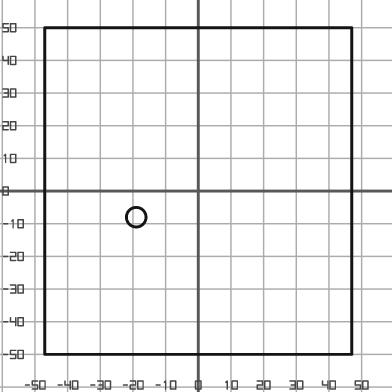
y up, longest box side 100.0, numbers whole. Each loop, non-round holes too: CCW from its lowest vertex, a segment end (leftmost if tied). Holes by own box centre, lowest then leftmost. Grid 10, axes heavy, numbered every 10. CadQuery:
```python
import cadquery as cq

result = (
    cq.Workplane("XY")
    .moveTo(-47.0, -50.0)
    .lineTo(47.0, -50.0)
    .lineTo(47.0, 50.0)
    .lineTo(-47.0, 50.0)
    .close()
    .moveTo(-19.0, -8.0)
    .circle(3.0)
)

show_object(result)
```